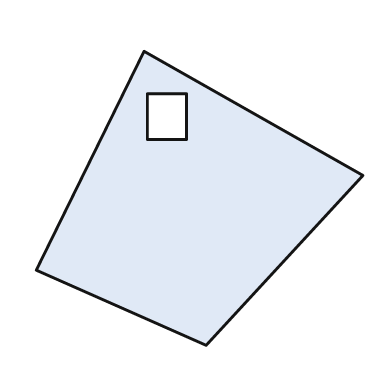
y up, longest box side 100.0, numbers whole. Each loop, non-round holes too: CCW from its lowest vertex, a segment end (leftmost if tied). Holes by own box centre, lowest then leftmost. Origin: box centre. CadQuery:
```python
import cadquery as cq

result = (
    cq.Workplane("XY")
    .moveTo(2.0, -45.0)
    .lineTo(50.0, 7.0)
    .lineTo(-17.0, 45.0)
    .lineTo(-50.0, -22.0)
    .close()
    .moveTo(-16.0, 18.0)
    .lineTo(-4.0, 18.0)
    .lineTo(-4.0, 32.0)
    .lineTo(-16.0, 32.0)
    .close()
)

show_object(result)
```